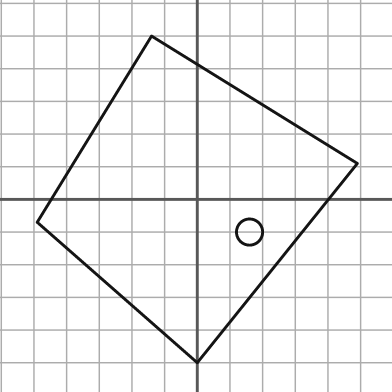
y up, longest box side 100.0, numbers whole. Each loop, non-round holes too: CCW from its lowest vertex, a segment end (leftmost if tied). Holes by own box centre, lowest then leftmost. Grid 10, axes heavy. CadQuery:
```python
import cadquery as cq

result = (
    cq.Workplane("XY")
    .moveTo(0.0, -50.0)
    .lineTo(49.0, 11.0)
    .lineTo(-14.0, 50.0)
    .lineTo(-49.0, -7.0)
    .close()
    .moveTo(16.0, -10.0)
    .circle(4.0)
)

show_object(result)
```